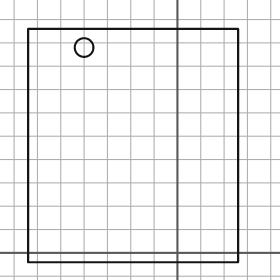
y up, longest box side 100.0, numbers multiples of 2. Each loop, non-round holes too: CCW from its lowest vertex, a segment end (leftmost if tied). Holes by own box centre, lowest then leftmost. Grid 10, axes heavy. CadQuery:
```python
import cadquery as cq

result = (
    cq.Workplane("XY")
    .moveTo(-64.0, -4.0)
    .lineTo(26.0, -4.0)
    .lineTo(26.0, 96.0)
    .lineTo(-64.0, 96.0)
    .close()
    .moveTo(-40.0, 88.0)
    .circle(4.0)
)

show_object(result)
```